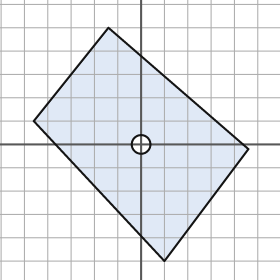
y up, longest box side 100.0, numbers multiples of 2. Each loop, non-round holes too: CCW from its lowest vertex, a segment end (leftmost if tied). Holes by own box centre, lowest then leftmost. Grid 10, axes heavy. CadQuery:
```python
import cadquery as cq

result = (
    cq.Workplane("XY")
    .moveTo(10.0, -50.0)
    .lineTo(46.0, -2.0)
    .lineTo(-14.0, 50.0)
    .lineTo(-46.0, 10.0)
    .close()
    .moveTo(0.0, 0.0)
    .circle(4.0)
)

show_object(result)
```